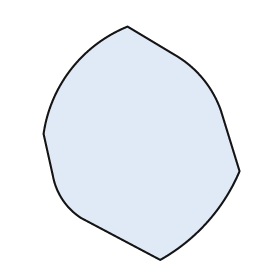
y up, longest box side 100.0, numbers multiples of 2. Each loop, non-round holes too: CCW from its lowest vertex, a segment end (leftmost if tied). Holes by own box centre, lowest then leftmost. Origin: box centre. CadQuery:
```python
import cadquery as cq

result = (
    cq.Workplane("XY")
    .moveTo(8.0, -50.0)
    .threePointArc((28.0, -34.0), (42.0, -12.0))
    .lineTo(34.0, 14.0)
    .threePointArc((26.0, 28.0), (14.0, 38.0))
    .lineTo(-6.0, 50.0)
    .threePointArc((-30.0, 32.0), (-42.0, 4.0))
    .lineTo(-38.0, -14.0)
    .threePointArc((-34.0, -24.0), (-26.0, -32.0))
    .close()
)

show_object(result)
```